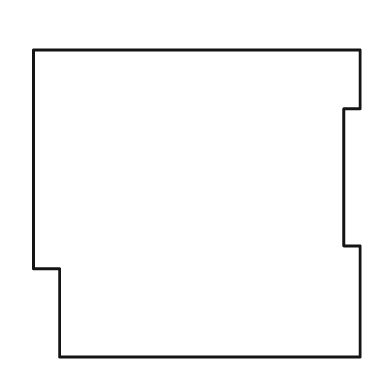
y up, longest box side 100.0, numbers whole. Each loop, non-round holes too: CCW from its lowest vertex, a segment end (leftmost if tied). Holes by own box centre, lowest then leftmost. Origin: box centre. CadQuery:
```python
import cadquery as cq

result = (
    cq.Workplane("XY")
    .moveTo(-42.0, -47.0)
    .lineTo(50.0, -47.0)
    .lineTo(50.0, -13.0)
    .lineTo(45.0, -13.0)
    .lineTo(45.0, 29.0)
    .lineTo(50.0, 29.0)
    .lineTo(50.0, 47.0)
    .lineTo(-50.0, 47.0)
    .lineTo(-50.0, -20.0)
    .lineTo(-42.0, -20.0)
    .close()
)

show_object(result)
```